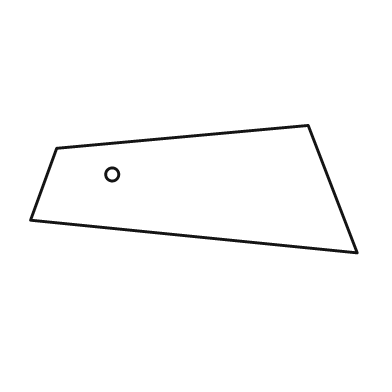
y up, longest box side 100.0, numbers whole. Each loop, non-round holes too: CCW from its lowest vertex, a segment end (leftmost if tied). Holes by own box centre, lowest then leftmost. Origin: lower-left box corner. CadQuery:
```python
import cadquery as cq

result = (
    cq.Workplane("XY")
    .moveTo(100.0, 0.0)
    .lineTo(85.0, 39.0)
    .lineTo(8.0, 32.0)
    .lineTo(0.0, 10.0)
    .close()
    .moveTo(25.0, 24.0)
    .circle(2.0)
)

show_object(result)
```